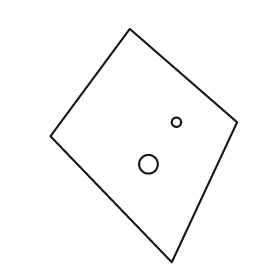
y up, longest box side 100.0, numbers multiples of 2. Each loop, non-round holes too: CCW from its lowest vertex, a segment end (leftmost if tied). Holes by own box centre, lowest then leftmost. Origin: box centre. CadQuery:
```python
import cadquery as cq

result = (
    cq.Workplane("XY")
    .moveTo(12.0, -50.0)
    .lineTo(40.0, 10.0)
    .lineTo(-6.0, 50.0)
    .lineTo(-40.0, 4.0)
    .close()
    .moveTo(2.0, -8.0)
    .circle(4.0)
    .moveTo(14.0, 10.0)
    .circle(2.0)
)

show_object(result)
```